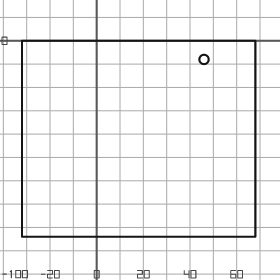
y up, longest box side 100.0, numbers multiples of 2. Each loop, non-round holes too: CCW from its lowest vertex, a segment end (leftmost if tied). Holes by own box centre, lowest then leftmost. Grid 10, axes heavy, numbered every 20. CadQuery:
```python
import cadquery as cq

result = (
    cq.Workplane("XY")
    .moveTo(-32.0, -84.0)
    .lineTo(68.0, -84.0)
    .lineTo(68.0, 0.0)
    .lineTo(-32.0, 0.0)
    .close()
    .moveTo(46.0, -8.0)
    .circle(2.0)
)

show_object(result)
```